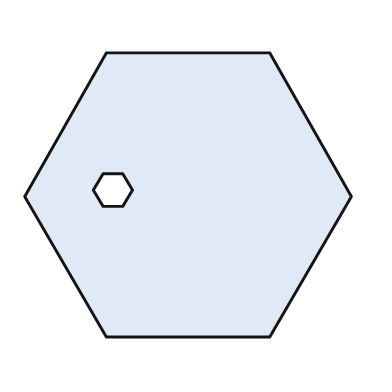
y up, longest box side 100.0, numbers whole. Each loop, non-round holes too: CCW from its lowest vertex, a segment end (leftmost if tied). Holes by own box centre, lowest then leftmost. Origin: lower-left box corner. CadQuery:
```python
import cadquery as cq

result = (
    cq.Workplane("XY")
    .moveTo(25.0, 0.0)
    .lineTo(75.0, 0.0)
    .lineTo(100.0, 43.0)
    .lineTo(75.0, 87.0)
    .lineTo(25.0, 87.0)
    .lineTo(0.0, 43.0)
    .close()
    .moveTo(24.0, 40.0)
    .lineTo(30.0, 40.0)
    .lineTo(33.0, 45.0)
    .lineTo(30.0, 50.0)
    .lineTo(24.0, 50.0)
    .lineTo(21.0, 45.0)
    .close()
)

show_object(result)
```